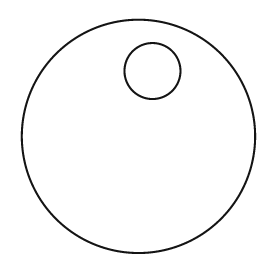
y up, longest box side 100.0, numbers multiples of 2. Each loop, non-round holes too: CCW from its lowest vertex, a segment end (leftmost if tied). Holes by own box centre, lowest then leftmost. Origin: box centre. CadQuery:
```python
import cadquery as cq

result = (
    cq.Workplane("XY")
    .moveTo(0.0, 0.0)
    .circle(50.0)
    .moveTo(6.0, 28.0)
    .circle(12.0)
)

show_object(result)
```